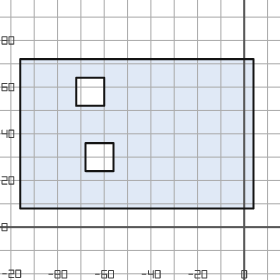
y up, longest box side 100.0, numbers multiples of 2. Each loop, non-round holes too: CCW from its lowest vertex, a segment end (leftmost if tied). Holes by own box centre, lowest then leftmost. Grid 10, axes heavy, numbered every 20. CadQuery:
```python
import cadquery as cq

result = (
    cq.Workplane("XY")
    .moveTo(-96.0, 8.0)
    .lineTo(4.0, 8.0)
    .lineTo(4.0, 72.0)
    .lineTo(-96.0, 72.0)
    .close()
    .moveTo(-68.0, 24.0)
    .lineTo(-56.0, 24.0)
    .lineTo(-56.0, 36.0)
    .lineTo(-68.0, 36.0)
    .close()
    .moveTo(-72.0, 52.0)
    .lineTo(-60.0, 52.0)
    .lineTo(-60.0, 64.0)
    .lineTo(-72.0, 64.0)
    .close()
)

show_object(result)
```